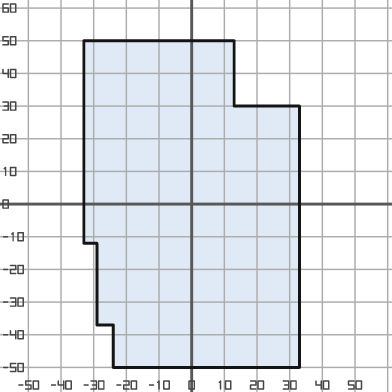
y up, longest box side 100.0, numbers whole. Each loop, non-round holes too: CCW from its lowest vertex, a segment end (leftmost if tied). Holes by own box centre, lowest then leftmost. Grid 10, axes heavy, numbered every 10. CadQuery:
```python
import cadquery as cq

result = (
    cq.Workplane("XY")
    .moveTo(-24.0, -50.0)
    .lineTo(33.0, -50.0)
    .lineTo(33.0, 30.0)
    .lineTo(13.0, 30.0)
    .lineTo(13.0, 50.0)
    .lineTo(-33.0, 50.0)
    .lineTo(-33.0, -12.0)
    .lineTo(-29.0, -12.0)
    .lineTo(-29.0, -37.0)
    .lineTo(-24.0, -37.0)
    .close()
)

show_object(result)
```